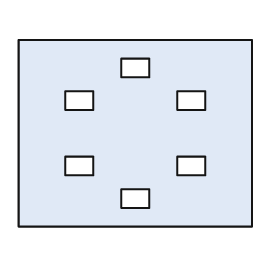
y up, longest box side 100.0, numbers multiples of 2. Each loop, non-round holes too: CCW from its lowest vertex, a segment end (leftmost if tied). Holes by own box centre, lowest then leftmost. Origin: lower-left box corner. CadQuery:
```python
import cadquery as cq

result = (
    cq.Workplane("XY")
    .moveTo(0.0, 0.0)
    .lineTo(100.0, 0.0)
    .lineTo(100.0, 80.0)
    .lineTo(0.0, 80.0)
    .close()
    .moveTo(44.0, 8.0)
    .lineTo(56.0, 8.0)
    .lineTo(56.0, 16.0)
    .lineTo(44.0, 16.0)
    .close()
    .moveTo(20.0, 22.0)
    .lineTo(32.0, 22.0)
    .lineTo(32.0, 30.0)
    .lineTo(20.0, 30.0)
    .close()
    .moveTo(68.0, 22.0)
    .lineTo(80.0, 22.0)
    .lineTo(80.0, 30.0)
    .lineTo(68.0, 30.0)
    .close()
    .moveTo(20.0, 50.0)
    .lineTo(32.0, 50.0)
    .lineTo(32.0, 58.0)
    .lineTo(20.0, 58.0)
    .close()
    .moveTo(68.0, 50.0)
    .lineTo(80.0, 50.0)
    .lineTo(80.0, 58.0)
    .lineTo(68.0, 58.0)
    .close()
    .moveTo(44.0, 64.0)
    .lineTo(56.0, 64.0)
    .lineTo(56.0, 72.0)
    .lineTo(44.0, 72.0)
    .close()
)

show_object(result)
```